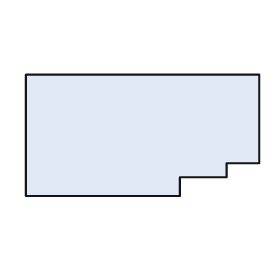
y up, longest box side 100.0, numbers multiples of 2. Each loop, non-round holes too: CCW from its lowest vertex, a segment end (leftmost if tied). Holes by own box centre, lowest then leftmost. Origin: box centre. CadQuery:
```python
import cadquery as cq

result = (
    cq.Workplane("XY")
    .moveTo(-50.0, -26.0)
    .lineTo(16.0, -26.0)
    .lineTo(16.0, -18.0)
    .lineTo(36.0, -18.0)
    .lineTo(36.0, -12.0)
    .lineTo(50.0, -12.0)
    .lineTo(50.0, 26.0)
    .lineTo(-50.0, 26.0)
    .close()
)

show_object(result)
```